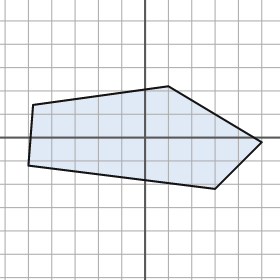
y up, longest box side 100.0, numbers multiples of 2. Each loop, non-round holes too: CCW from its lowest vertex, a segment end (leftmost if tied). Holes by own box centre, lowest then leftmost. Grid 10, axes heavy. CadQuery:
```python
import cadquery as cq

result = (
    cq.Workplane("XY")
    .moveTo(30.0, -22.0)
    .lineTo(50.0, -2.0)
    .lineTo(10.0, 22.0)
    .lineTo(-48.0, 14.0)
    .lineTo(-50.0, -12.0)
    .close()
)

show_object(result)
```